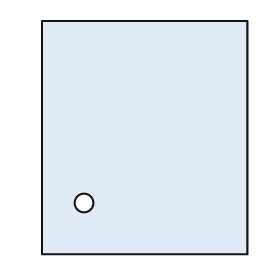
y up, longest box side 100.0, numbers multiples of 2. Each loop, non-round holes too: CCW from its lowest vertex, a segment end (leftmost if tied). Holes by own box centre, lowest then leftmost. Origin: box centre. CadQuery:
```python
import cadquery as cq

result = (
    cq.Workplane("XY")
    .moveTo(-44.0, -50.0)
    .lineTo(44.0, -50.0)
    .lineTo(44.0, 50.0)
    .lineTo(-44.0, 50.0)
    .close()
    .moveTo(-26.0, -28.0)
    .circle(4.0)
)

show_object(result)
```